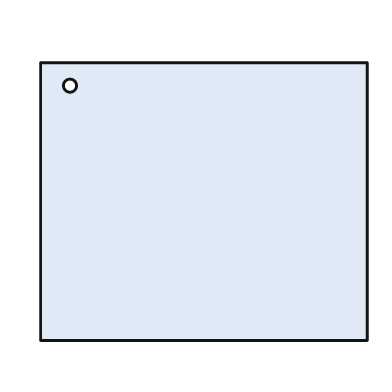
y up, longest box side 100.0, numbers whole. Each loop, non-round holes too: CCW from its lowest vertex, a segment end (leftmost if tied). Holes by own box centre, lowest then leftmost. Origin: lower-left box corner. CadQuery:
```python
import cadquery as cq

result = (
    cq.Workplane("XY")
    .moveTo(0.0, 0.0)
    .lineTo(100.0, 0.0)
    .lineTo(100.0, 85.0)
    .lineTo(0.0, 85.0)
    .close()
    .moveTo(9.0, 78.0)
    .circle(2.0)
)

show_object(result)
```